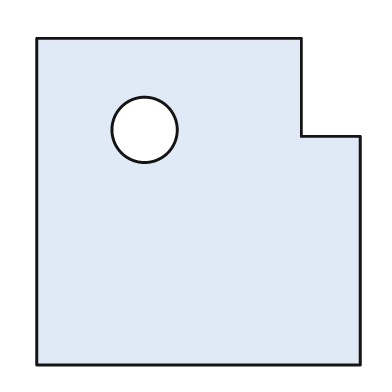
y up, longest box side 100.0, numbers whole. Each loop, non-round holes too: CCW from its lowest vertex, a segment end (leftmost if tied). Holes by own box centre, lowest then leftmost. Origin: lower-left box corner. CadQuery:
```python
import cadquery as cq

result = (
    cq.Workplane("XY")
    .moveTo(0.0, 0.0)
    .lineTo(99.0, 0.0)
    .lineTo(99.0, 70.0)
    .lineTo(81.0, 70.0)
    .lineTo(81.0, 100.0)
    .lineTo(0.0, 100.0)
    .close()
    .moveTo(33.0, 72.0)
    .circle(10.0)
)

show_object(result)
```